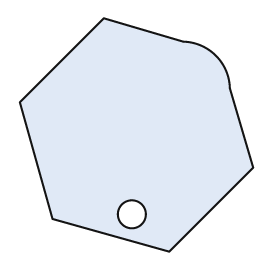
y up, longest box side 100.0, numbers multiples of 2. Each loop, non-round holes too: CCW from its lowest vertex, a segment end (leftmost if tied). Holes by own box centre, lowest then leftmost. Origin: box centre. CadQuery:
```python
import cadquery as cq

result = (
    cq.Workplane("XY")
    .moveTo(14.0, -50.0)
    .lineTo(50.0, -14.0)
    .lineTo(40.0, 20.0)
    .threePointArc((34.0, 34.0), (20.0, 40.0))
    .lineTo(-14.0, 50.0)
    .lineTo(-50.0, 14.0)
    .lineTo(-36.0, -36.0)
    .close()
    .moveTo(-2.0, -34.0)
    .circle(6.0)
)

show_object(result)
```